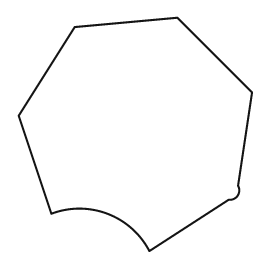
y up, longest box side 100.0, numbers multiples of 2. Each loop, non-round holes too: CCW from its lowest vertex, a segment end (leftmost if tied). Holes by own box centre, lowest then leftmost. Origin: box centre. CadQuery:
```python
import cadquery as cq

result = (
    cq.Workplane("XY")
    .moveTo(6.0, -50.0)
    .lineTo(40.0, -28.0)
    .threePointArc((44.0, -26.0), (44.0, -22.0))
    .lineTo(50.0, 18.0)
    .lineTo(18.0, 50.0)
    .lineTo(-26.0, 46.0)
    .lineTo(-50.0, 8.0)
    .lineTo(-36.0, -34.0)
    .threePointArc((-12.0, -34.0), (6.0, -50.0))
    .close()
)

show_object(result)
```